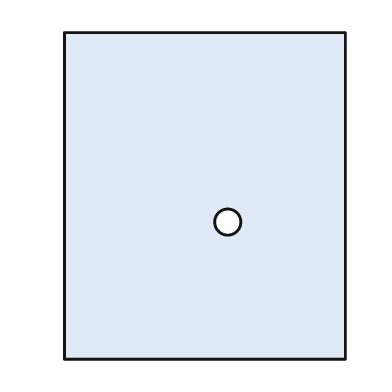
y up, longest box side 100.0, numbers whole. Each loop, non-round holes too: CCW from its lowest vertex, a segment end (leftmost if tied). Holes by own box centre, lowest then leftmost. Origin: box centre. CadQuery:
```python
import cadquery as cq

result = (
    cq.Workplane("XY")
    .moveTo(-43.0, -50.0)
    .lineTo(43.0, -50.0)
    .lineTo(43.0, 50.0)
    .lineTo(-43.0, 50.0)
    .close()
    .moveTo(7.0, -8.0)
    .circle(4.0)
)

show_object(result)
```